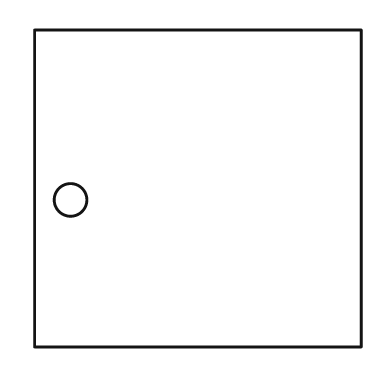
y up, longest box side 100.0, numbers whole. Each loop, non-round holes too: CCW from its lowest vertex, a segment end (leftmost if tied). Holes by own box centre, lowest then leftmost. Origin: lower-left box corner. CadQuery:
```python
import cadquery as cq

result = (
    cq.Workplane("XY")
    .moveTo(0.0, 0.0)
    .lineTo(100.0, 0.0)
    .lineTo(100.0, 97.0)
    .lineTo(0.0, 97.0)
    .close()
    .moveTo(11.0, 45.0)
    .circle(5.0)
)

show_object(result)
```